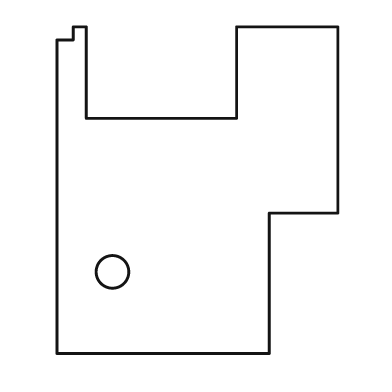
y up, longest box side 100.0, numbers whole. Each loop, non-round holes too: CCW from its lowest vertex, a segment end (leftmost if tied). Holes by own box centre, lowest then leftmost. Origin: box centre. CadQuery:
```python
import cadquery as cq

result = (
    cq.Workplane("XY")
    .moveTo(-43.0, -50.0)
    .lineTo(22.0, -50.0)
    .lineTo(22.0, -7.0)
    .lineTo(43.0, -7.0)
    .lineTo(43.0, 50.0)
    .lineTo(12.0, 50.0)
    .lineTo(12.0, 22.0)
    .lineTo(-34.0, 22.0)
    .lineTo(-34.0, 50.0)
    .lineTo(-38.0, 50.0)
    .lineTo(-38.0, 46.0)
    .lineTo(-43.0, 46.0)
    .close()
    .moveTo(-26.0, -25.0)
    .circle(5.0)
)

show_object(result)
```